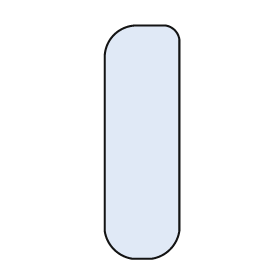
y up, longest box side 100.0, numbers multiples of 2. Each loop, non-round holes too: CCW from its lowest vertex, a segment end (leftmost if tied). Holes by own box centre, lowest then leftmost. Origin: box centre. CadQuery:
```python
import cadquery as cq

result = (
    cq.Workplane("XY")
    .moveTo(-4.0, -50.0)
    .lineTo(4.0, -50.0)
    .threePointArc((12.0, -46.0), (16.0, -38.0))
    .lineTo(16.0, 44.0)
    .threePointArc((14.0, 48.0), (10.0, 50.0))
    .lineTo(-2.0, 50.0)
    .threePointArc((-12.0, 46.0), (-16.0, 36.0))
    .lineTo(-16.0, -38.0)
    .threePointArc((-12.0, -46.0), (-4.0, -50.0))
    .close()
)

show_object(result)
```